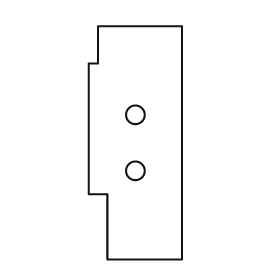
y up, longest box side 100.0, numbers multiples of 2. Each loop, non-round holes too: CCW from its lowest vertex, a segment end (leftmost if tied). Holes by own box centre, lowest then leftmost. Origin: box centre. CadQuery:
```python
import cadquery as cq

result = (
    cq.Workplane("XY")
    .moveTo(-12.0, -50.0)
    .lineTo(20.0, -50.0)
    .lineTo(20.0, 50.0)
    .lineTo(-16.0, 50.0)
    .lineTo(-16.0, 34.0)
    .lineTo(-20.0, 34.0)
    .lineTo(-20.0, -22.0)
    .lineTo(-12.0, -22.0)
    .close()
    .moveTo(0.0, -12.0)
    .circle(4.0)
    .moveTo(0.0, 12.0)
    .circle(4.0)
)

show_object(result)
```